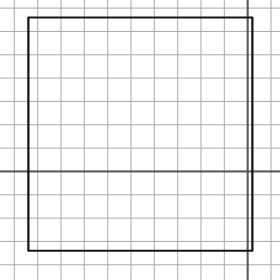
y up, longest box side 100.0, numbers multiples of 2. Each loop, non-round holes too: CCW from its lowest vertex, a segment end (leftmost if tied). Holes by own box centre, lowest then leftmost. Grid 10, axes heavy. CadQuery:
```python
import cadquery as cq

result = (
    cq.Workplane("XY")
    .moveTo(-94.0, -34.0)
    .lineTo(2.0, -34.0)
    .lineTo(2.0, 66.0)
    .lineTo(-94.0, 66.0)
    .close()
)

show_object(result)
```